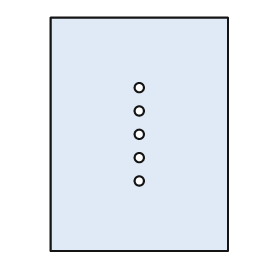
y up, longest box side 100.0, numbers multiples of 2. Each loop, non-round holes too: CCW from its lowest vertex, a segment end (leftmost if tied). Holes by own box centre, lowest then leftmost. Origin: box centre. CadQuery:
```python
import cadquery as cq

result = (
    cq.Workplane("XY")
    .moveTo(-38.0, -50.0)
    .lineTo(38.0, -50.0)
    .lineTo(38.0, 50.0)
    .lineTo(-38.0, 50.0)
    .close()
    .moveTo(0.0, -20.0)
    .circle(2.0)
    .moveTo(0.0, -10.0)
    .circle(2.0)
    .moveTo(0.0, 0.0)
    .circle(2.0)
    .moveTo(0.0, 10.0)
    .circle(2.0)
    .moveTo(0.0, 20.0)
    .circle(2.0)
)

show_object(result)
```